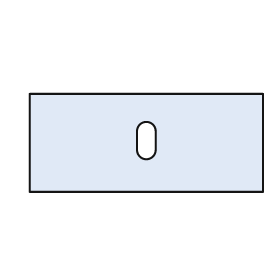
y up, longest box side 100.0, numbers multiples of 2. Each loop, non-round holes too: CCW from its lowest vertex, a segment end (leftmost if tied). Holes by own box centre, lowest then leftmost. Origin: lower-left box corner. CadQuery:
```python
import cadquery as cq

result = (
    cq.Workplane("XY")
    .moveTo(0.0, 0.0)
    .lineTo(100.0, 0.0)
    .lineTo(100.0, 42.0)
    .lineTo(0.0, 42.0)
    .close()
    .moveTo(46.0, 18.0)
    .threePointArc((50.0, 14.0), (54.0, 18.0))
    .lineTo(54.0, 26.0)
    .threePointArc((50.0, 30.0), (46.0, 26.0))
    .close()
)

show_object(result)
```